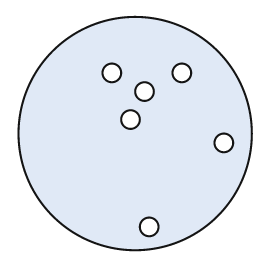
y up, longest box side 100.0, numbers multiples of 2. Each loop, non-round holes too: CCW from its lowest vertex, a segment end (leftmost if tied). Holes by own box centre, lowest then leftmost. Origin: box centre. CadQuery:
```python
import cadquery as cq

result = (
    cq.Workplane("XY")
    .moveTo(0.0, 0.0)
    .circle(50.0)
    .moveTo(6.0, -40.0)
    .circle(4.0)
    .moveTo(38.0, -4.0)
    .circle(4.0)
    .moveTo(-2.0, 6.0)
    .circle(4.0)
    .moveTo(4.0, 18.0)
    .circle(4.0)
    .moveTo(-10.0, 26.0)
    .circle(4.0)
    .moveTo(20.0, 26.0)
    .circle(4.0)
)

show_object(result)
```